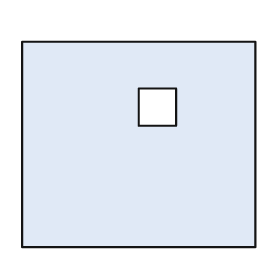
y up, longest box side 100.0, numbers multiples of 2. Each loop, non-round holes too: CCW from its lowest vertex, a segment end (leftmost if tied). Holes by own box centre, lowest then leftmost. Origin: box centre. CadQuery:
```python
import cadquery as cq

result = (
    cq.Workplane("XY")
    .moveTo(-50.0, -44.0)
    .lineTo(50.0, -44.0)
    .lineTo(50.0, 44.0)
    .lineTo(-50.0, 44.0)
    .close()
    .moveTo(0.0, 8.0)
    .lineTo(16.0, 8.0)
    .lineTo(16.0, 24.0)
    .lineTo(0.0, 24.0)
    .close()
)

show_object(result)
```